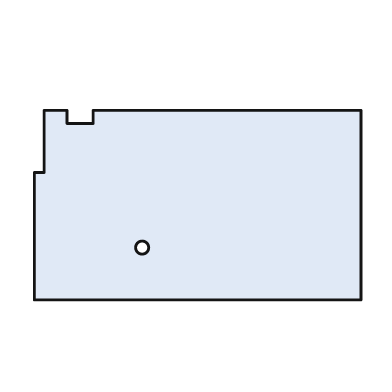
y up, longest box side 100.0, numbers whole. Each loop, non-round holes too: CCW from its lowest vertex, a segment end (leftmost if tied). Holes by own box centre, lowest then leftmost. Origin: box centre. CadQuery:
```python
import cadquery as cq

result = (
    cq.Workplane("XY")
    .moveTo(-50.0, -29.0)
    .lineTo(50.0, -29.0)
    .lineTo(50.0, 29.0)
    .lineTo(-32.0, 29.0)
    .lineTo(-32.0, 25.0)
    .lineTo(-40.0, 25.0)
    .lineTo(-40.0, 29.0)
    .lineTo(-47.0, 29.0)
    .lineTo(-47.0, 10.0)
    .lineTo(-50.0, 10.0)
    .close()
    .moveTo(-17.0, -13.0)
    .circle(2.0)
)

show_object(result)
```